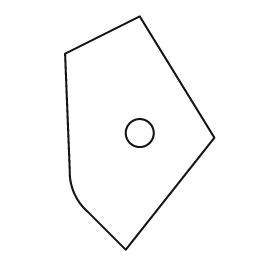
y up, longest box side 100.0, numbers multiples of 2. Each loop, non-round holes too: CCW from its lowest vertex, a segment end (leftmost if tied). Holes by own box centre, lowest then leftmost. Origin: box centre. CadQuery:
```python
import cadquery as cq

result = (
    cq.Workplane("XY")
    .moveTo(-6.0, -50.0)
    .lineTo(32.0, -2.0)
    .lineTo(0.0, 50.0)
    .lineTo(-32.0, 34.0)
    .lineTo(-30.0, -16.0)
    .threePointArc((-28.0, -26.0), (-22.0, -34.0))
    .close()
    .moveTo(0.0, 0.0)
    .circle(6.0)
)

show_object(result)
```